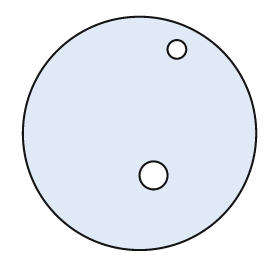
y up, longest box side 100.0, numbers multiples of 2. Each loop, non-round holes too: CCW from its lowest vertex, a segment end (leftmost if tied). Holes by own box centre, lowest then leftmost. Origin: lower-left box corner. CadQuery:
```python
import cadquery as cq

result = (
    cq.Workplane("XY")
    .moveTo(50.0, 50.0)
    .circle(50.0)
    .moveTo(56.0, 32.0)
    .circle(6.0)
    .moveTo(66.0, 86.0)
    .circle(4.0)
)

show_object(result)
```